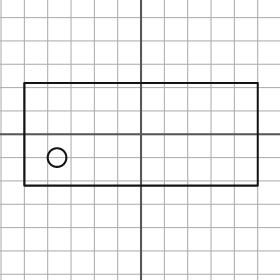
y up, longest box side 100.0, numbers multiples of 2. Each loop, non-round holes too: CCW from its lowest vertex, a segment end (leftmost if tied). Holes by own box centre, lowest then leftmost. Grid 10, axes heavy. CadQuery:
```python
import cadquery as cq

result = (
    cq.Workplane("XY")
    .moveTo(-50.0, -22.0)
    .lineTo(50.0, -22.0)
    .lineTo(50.0, 22.0)
    .lineTo(-50.0, 22.0)
    .close()
    .moveTo(-36.0, -10.0)
    .circle(4.0)
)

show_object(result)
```